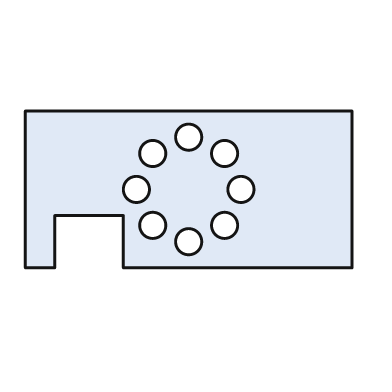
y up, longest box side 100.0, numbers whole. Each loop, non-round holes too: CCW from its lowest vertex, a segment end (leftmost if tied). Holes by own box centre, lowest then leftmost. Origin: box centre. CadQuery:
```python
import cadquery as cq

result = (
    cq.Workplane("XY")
    .moveTo(-50.0, -24.0)
    .lineTo(-41.0, -24.0)
    .lineTo(-41.0, -8.0)
    .lineTo(-20.0, -8.0)
    .lineTo(-20.0, -24.0)
    .lineTo(50.0, -24.0)
    .lineTo(50.0, 24.0)
    .lineTo(-50.0, 24.0)
    .close()
    .moveTo(0.0, -16.0)
    .circle(4.0)
    .moveTo(-11.0, -11.0)
    .circle(4.0)
    .moveTo(11.0, -11.0)
    .circle(4.0)
    .moveTo(-16.0, 0.0)
    .circle(4.0)
    .moveTo(16.0, 0.0)
    .circle(4.0)
    .moveTo(-11.0, 11.0)
    .circle(4.0)
    .moveTo(11.0, 11.0)
    .circle(4.0)
    .moveTo(0.0, 16.0)
    .circle(4.0)
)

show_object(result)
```